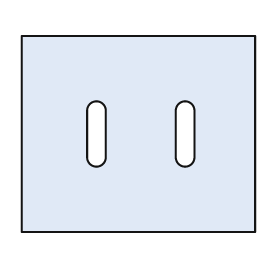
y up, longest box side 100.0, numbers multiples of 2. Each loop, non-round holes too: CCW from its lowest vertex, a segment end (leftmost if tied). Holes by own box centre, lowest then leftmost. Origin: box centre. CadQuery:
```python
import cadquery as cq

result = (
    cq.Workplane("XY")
    .moveTo(-50.0, -42.0)
    .lineTo(50.0, -42.0)
    .lineTo(50.0, 42.0)
    .lineTo(-50.0, 42.0)
    .close()
    .moveTo(-22.0, -10.0)
    .threePointArc((-18.0, -14.0), (-14.0, -10.0))
    .lineTo(-14.0, 10.0)
    .threePointArc((-18.0, 14.0), (-22.0, 10.0))
    .close()
    .moveTo(16.0, -10.0)
    .threePointArc((20.0, -14.0), (24.0, -10.0))
    .lineTo(24.0, 10.0)
    .threePointArc((20.0, 14.0), (16.0, 10.0))
    .close()
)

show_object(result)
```